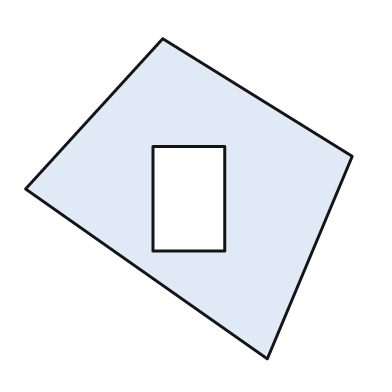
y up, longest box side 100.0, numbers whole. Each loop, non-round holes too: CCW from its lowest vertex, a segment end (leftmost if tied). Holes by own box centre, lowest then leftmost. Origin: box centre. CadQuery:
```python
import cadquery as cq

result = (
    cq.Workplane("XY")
    .moveTo(24.0, -49.0)
    .lineTo(50.0, 13.0)
    .lineTo(-8.0, 49.0)
    .lineTo(-50.0, 3.0)
    .close()
    .moveTo(-11.0, -16.0)
    .lineTo(11.0, -16.0)
    .lineTo(11.0, 16.0)
    .lineTo(-11.0, 16.0)
    .close()
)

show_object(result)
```